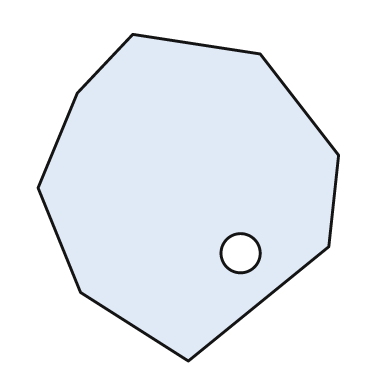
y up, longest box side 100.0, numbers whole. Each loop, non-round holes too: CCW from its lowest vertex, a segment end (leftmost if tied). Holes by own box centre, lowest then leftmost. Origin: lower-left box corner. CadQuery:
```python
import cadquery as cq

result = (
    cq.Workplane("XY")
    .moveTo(46.0, 0.0)
    .lineTo(89.0, 35.0)
    .lineTo(92.0, 63.0)
    .lineTo(68.0, 94.0)
    .lineTo(29.0, 100.0)
    .lineTo(12.0, 82.0)
    .lineTo(0.0, 53.0)
    .lineTo(13.0, 21.0)
    .close()
    .moveTo(62.0, 33.0)
    .circle(6.0)
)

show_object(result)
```